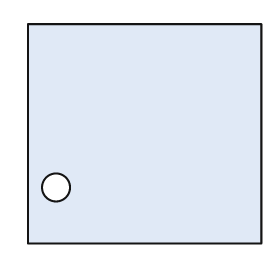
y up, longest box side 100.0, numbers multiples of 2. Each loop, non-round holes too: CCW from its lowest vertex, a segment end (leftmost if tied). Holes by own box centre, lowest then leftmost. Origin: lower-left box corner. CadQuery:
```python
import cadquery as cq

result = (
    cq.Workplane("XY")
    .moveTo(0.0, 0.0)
    .lineTo(100.0, 0.0)
    .lineTo(100.0, 94.0)
    .lineTo(0.0, 94.0)
    .close()
    .moveTo(12.0, 24.0)
    .circle(6.0)
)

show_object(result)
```